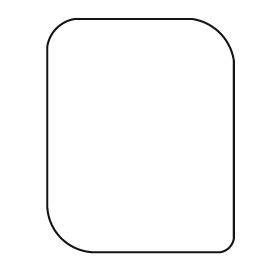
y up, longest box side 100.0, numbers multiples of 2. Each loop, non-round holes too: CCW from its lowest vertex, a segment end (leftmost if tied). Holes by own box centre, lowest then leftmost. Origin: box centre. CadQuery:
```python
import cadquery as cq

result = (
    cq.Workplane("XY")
    .moveTo(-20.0, -50.0)
    .lineTo(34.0, -50.0)
    .threePointArc((38.0, -48.0), (40.0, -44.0))
    .lineTo(40.0, 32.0)
    .threePointArc((34.0, 44.0), (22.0, 50.0))
    .lineTo(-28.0, 50.0)
    .threePointArc((-36.0, 46.0), (-40.0, 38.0))
    .lineTo(-40.0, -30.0)
    .threePointArc((-34.0, -44.0), (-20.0, -50.0))
    .close()
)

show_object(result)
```